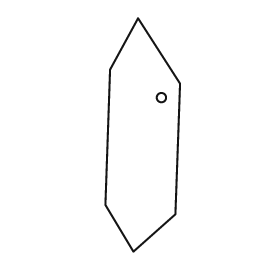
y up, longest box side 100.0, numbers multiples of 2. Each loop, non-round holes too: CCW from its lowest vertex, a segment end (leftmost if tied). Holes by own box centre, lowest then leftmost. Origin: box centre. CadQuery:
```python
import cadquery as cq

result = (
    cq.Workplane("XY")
    .moveTo(-4.0, -50.0)
    .lineTo(14.0, -34.0)
    .lineTo(16.0, 22.0)
    .lineTo(-2.0, 50.0)
    .lineTo(-14.0, 28.0)
    .lineTo(-16.0, -30.0)
    .close()
    .moveTo(8.0, 16.0)
    .circle(2.0)
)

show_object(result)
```